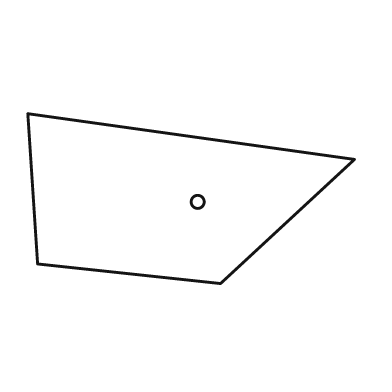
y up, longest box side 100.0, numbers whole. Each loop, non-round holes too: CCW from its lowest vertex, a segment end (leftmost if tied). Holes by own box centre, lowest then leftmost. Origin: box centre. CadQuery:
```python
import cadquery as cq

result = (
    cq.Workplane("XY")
    .moveTo(9.0, -26.0)
    .lineTo(50.0, 12.0)
    .lineTo(-50.0, 26.0)
    .lineTo(-47.0, -20.0)
    .close()
    .moveTo(2.0, -1.0)
    .circle(2.0)
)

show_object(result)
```